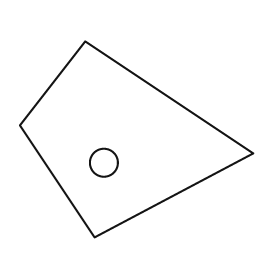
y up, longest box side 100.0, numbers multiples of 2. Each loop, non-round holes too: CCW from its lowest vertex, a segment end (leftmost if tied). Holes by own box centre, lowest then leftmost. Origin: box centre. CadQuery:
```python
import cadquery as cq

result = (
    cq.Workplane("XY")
    .moveTo(-18.0, -42.0)
    .lineTo(50.0, -6.0)
    .lineTo(-22.0, 42.0)
    .lineTo(-50.0, 6.0)
    .close()
    .moveTo(-14.0, -10.0)
    .circle(6.0)
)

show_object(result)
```